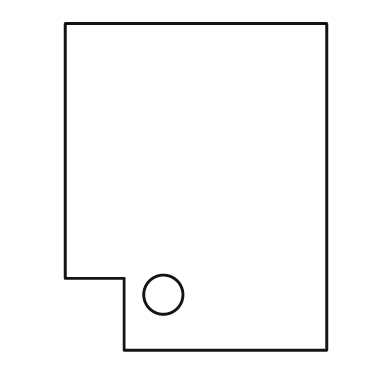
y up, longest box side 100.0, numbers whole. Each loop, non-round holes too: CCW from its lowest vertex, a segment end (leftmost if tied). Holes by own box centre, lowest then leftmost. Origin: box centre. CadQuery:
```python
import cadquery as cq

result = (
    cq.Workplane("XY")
    .moveTo(-22.0, -50.0)
    .lineTo(40.0, -50.0)
    .lineTo(40.0, 50.0)
    .lineTo(-40.0, 50.0)
    .lineTo(-40.0, -28.0)
    .lineTo(-22.0, -28.0)
    .close()
    .moveTo(-10.0, -33.0)
    .circle(6.0)
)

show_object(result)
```